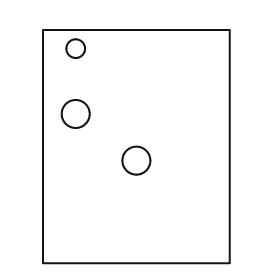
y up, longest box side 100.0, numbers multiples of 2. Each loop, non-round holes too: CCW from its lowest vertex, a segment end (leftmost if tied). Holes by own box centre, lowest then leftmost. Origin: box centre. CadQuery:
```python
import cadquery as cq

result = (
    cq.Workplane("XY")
    .moveTo(-40.0, -50.0)
    .lineTo(40.0, -50.0)
    .lineTo(40.0, 50.0)
    .lineTo(-40.0, 50.0)
    .close()
    .moveTo(0.0, -6.0)
    .circle(6.0)
    .moveTo(-26.0, 14.0)
    .circle(6.0)
    .moveTo(-26.0, 42.0)
    .circle(4.0)
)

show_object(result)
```